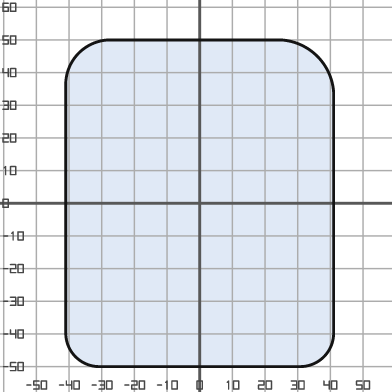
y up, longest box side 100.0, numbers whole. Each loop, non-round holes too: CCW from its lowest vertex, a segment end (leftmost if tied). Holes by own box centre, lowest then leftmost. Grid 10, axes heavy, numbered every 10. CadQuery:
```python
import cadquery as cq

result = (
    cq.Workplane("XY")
    .moveTo(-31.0, -50.0)
    .lineTo(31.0, -50.0)
    .threePointArc((38.0, -47.0), (41.0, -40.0))
    .lineTo(41.0, 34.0)
    .threePointArc((36.0, 45.0), (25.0, 50.0))
    .lineTo(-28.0, 50.0)
    .threePointArc((-37.0, 46.0), (-41.0, 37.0))
    .lineTo(-41.0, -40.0)
    .threePointArc((-38.0, -47.0), (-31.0, -50.0))
    .close()
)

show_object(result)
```